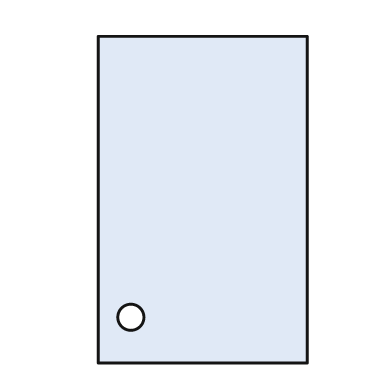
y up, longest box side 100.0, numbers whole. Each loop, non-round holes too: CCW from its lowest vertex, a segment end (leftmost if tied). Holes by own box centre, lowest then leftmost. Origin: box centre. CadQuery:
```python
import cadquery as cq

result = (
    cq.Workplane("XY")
    .moveTo(-32.0, -50.0)
    .lineTo(32.0, -50.0)
    .lineTo(32.0, 50.0)
    .lineTo(-32.0, 50.0)
    .close()
    .moveTo(-22.0, -36.0)
    .circle(4.0)
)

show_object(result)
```